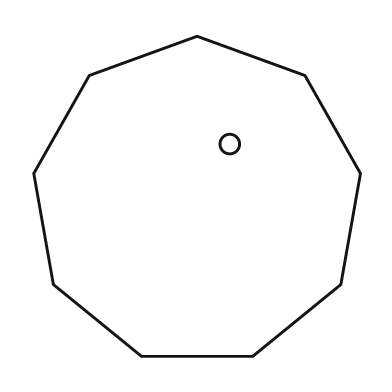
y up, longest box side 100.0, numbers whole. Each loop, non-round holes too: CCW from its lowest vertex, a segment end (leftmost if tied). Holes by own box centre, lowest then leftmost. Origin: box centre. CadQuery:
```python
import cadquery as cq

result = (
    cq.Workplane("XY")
    .moveTo(-17.0, -49.0)
    .lineTo(17.0, -49.0)
    .lineTo(44.0, -27.0)
    .lineTo(50.0, 7.0)
    .lineTo(33.0, 37.0)
    .lineTo(0.0, 49.0)
    .lineTo(-33.0, 37.0)
    .lineTo(-50.0, 7.0)
    .lineTo(-44.0, -27.0)
    .close()
    .moveTo(10.0, 16.0)
    .circle(3.0)
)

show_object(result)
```